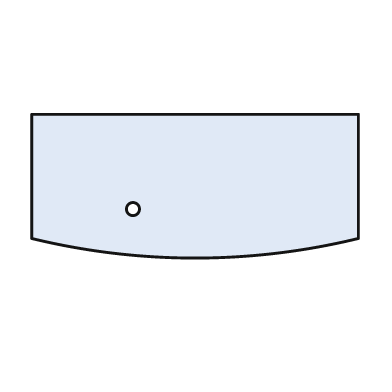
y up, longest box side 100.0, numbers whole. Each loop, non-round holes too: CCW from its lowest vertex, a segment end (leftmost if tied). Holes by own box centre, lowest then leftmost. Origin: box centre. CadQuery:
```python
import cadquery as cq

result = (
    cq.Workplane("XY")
    .moveTo(-50.0, -16.0)
    .threePointArc((0.0, -22.0), (50.0, -16.0))
    .lineTo(50.0, 22.0)
    .lineTo(-50.0, 22.0)
    .close()
    .moveTo(-19.0, -7.0)
    .circle(2.0)
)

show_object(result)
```